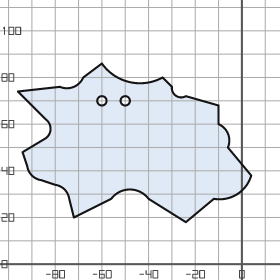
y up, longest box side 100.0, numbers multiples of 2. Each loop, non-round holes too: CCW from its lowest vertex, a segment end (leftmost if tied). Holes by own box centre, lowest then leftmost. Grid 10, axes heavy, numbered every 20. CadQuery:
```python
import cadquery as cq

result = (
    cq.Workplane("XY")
    .moveTo(-24.0, 18.0)
    .lineTo(-12.0, 28.0)
    .threePointArc((-2.0, 30.0), (4.0, 38.0))
    .lineTo(-6.0, 50.0)
    .threePointArc((-6.0, 56.0), (-10.0, 60.0))
    .lineTo(-10.0, 68.0)
    .lineTo(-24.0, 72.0)
    .threePointArc((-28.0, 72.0), (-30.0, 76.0))
    .lineTo(-34.0, 80.0)
    .threePointArc((-48.0, 78.0), (-60.0, 86.0))
    .lineTo(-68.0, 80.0)
    .threePointArc((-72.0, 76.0), (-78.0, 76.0))
    .lineTo(-96.0, 74.0)
    .lineTo(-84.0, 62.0)
    .threePointArc((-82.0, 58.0), (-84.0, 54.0))
    .lineTo(-94.0, 48.0)
    .lineTo(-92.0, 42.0)
    .threePointArc((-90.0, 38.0), (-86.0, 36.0))
    .lineTo(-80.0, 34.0)
    .threePointArc((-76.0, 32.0), (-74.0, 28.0))
    .lineTo(-72.0, 20.0)
    .lineTo(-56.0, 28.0)
    .threePointArc((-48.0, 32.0), (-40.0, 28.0))
    .close()
    .moveTo(-60.0, 70.0)
    .circle(2.0)
    .moveTo(-50.0, 70.0)
    .circle(2.0)
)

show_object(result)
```